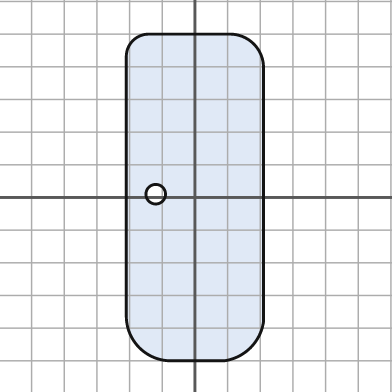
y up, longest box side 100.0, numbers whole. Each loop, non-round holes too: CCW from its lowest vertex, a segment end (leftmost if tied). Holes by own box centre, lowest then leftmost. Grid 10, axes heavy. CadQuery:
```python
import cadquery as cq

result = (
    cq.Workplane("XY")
    .moveTo(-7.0, -50.0)
    .lineTo(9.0, -50.0)
    .threePointArc((17.0, -46.0), (21.0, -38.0))
    .lineTo(21.0, 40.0)
    .threePointArc((18.0, 47.0), (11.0, 50.0))
    .lineTo(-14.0, 50.0)
    .threePointArc((-19.0, 48.0), (-21.0, 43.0))
    .lineTo(-21.0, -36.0)
    .threePointArc((-17.0, -46.0), (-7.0, -50.0))
    .close()
    .moveTo(-12.0, 1.0)
    .circle(3.0)
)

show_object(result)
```